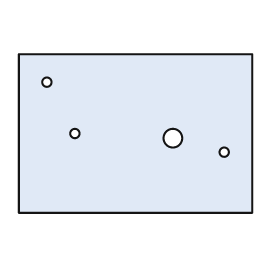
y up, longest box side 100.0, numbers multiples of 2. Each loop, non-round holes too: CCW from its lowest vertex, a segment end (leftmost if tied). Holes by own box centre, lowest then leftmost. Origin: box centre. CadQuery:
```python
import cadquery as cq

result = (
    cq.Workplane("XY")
    .moveTo(-50.0, -34.0)
    .lineTo(50.0, -34.0)
    .lineTo(50.0, 34.0)
    .lineTo(-50.0, 34.0)
    .close()
    .moveTo(38.0, -8.0)
    .circle(2.0)
    .moveTo(16.0, -2.0)
    .circle(4.0)
    .moveTo(-26.0, 0.0)
    .circle(2.0)
    .moveTo(-38.0, 22.0)
    .circle(2.0)
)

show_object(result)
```